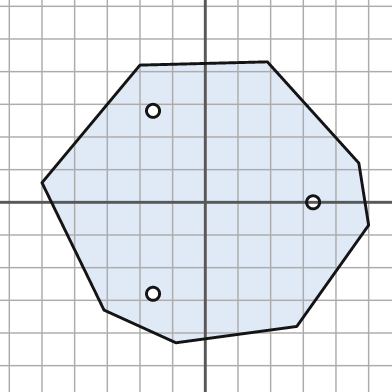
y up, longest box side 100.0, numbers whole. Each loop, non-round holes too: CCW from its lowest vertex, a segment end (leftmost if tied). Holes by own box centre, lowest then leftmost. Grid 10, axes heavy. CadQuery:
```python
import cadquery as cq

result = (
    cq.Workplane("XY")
    .moveTo(-9.0, -43.0)
    .lineTo(28.0, -38.0)
    .lineTo(50.0, -7.0)
    .lineTo(47.0, 12.0)
    .lineTo(19.0, 43.0)
    .lineTo(-20.0, 42.0)
    .lineTo(-50.0, 6.0)
    .lineTo(-31.0, -33.0)
    .close()
    .moveTo(-16.0, -28.0)
    .circle(2.0)
    .moveTo(33.0, 0.0)
    .circle(2.0)
    .moveTo(-16.0, 28.0)
    .circle(2.0)
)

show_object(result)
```